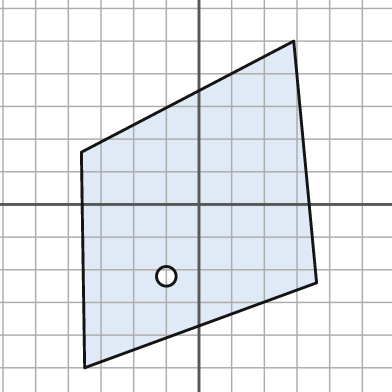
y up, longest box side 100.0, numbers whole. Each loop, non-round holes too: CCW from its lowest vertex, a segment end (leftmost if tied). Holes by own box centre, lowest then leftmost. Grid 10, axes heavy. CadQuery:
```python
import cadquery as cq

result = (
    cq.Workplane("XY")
    .moveTo(-35.0, -50.0)
    .lineTo(36.0, -24.0)
    .lineTo(29.0, 50.0)
    .lineTo(-36.0, 16.0)
    .close()
    .moveTo(-10.0, -22.0)
    .circle(3.0)
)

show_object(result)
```